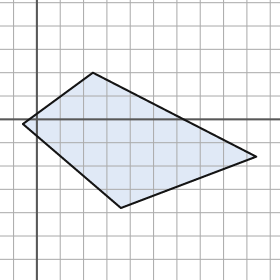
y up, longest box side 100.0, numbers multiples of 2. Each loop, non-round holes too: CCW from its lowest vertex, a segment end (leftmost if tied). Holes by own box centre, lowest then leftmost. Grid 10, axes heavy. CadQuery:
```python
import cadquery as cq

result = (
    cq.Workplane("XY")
    .moveTo(36.0, -38.0)
    .lineTo(94.0, -16.0)
    .lineTo(24.0, 20.0)
    .lineTo(-6.0, -2.0)
    .close()
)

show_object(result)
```